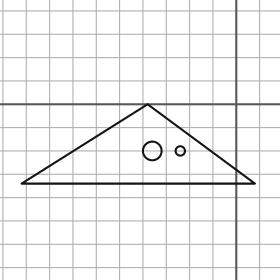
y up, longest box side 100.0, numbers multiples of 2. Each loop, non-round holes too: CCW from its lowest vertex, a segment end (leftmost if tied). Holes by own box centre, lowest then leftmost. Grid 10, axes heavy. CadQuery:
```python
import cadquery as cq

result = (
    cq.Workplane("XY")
    .moveTo(-92.0, -34.0)
    .lineTo(8.0, -34.0)
    .lineTo(-38.0, 0.0)
    .close()
    .moveTo(-36.0, -20.0)
    .circle(4.0)
    .moveTo(-24.0, -20.0)
    .circle(2.0)
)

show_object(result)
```